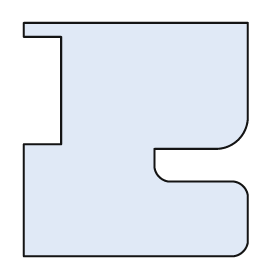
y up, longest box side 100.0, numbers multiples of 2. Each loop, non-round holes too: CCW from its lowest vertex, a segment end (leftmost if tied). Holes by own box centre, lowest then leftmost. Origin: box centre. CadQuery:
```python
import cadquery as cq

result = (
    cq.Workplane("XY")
    .moveTo(-48.0, -50.0)
    .lineTo(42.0, -50.0)
    .threePointArc((46.0, -48.0), (48.0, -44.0))
    .lineTo(48.0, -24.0)
    .threePointArc((46.0, -20.0), (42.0, -18.0))
    .lineTo(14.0, -18.0)
    .threePointArc((10.0, -16.0), (8.0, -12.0))
    .lineTo(8.0, -4.0)
    .lineTo(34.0, -4.0)
    .threePointArc((44.0, 0.0), (48.0, 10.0))
    .lineTo(48.0, 50.0)
    .lineTo(-48.0, 50.0)
    .lineTo(-48.0, 44.0)
    .lineTo(-32.0, 44.0)
    .lineTo(-32.0, -2.0)
    .lineTo(-48.0, -2.0)
    .close()
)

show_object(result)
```